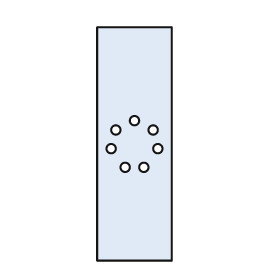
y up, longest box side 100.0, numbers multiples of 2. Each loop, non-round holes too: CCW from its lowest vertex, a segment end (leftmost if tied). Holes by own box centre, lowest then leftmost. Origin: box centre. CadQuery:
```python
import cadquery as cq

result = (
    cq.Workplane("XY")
    .moveTo(-16.0, -50.0)
    .lineTo(16.0, -50.0)
    .lineTo(16.0, 50.0)
    .lineTo(-16.0, 50.0)
    .close()
    .moveTo(-4.0, -10.0)
    .circle(2.0)
    .moveTo(4.0, -10.0)
    .circle(2.0)
    .moveTo(-10.0, -2.0)
    .circle(2.0)
    .moveTo(10.0, -2.0)
    .circle(2.0)
    .moveTo(-8.0, 6.0)
    .circle(2.0)
    .moveTo(8.0, 6.0)
    .circle(2.0)
    .moveTo(0.0, 10.0)
    .circle(2.0)
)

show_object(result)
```